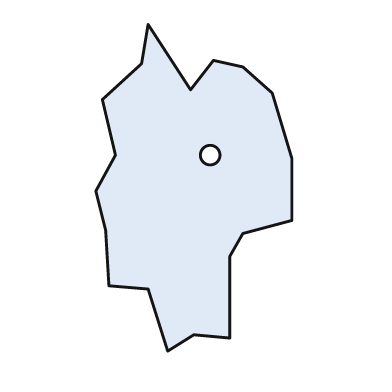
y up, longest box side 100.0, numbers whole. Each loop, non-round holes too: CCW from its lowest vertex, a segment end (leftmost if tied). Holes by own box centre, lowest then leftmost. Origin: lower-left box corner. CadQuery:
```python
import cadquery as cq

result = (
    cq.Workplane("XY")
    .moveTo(22.0, 0.0)
    .lineTo(30.0, 5.0)
    .lineTo(41.0, 4.0)
    .lineTo(41.0, 29.0)
    .lineTo(45.0, 36.0)
    .lineTo(60.0, 40.0)
    .lineTo(60.0, 59.0)
    .lineTo(54.0, 79.0)
    .lineTo(45.0, 87.0)
    .lineTo(36.0, 89.0)
    .lineTo(29.0, 80.0)
    .lineTo(16.0, 100.0)
    .lineTo(14.0, 88.0)
    .lineTo(2.0, 77.0)
    .lineTo(6.0, 60.0)
    .lineTo(0.0, 49.0)
    .lineTo(3.0, 37.0)
    .lineTo(4.0, 20.0)
    .lineTo(16.0, 19.0)
    .close()
    .moveTo(35.0, 60.0)
    .circle(3.0)
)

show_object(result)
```